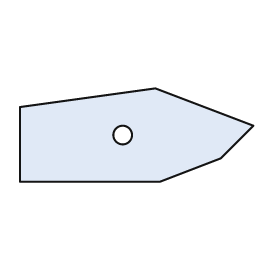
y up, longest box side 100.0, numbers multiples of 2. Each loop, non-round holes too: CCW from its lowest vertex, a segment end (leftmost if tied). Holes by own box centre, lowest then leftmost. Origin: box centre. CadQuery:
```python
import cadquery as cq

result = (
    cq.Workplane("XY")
    .moveTo(-50.0, -20.0)
    .lineTo(10.0, -20.0)
    .lineTo(36.0, -10.0)
    .lineTo(50.0, 4.0)
    .lineTo(8.0, 20.0)
    .lineTo(-50.0, 12.0)
    .close()
    .moveTo(-6.0, 0.0)
    .circle(4.0)
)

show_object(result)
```